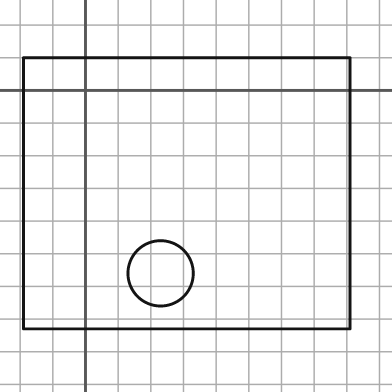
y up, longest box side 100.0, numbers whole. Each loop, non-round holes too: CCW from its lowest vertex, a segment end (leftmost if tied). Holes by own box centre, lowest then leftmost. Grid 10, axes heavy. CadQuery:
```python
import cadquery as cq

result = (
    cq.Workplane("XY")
    .moveTo(-19.0, -73.0)
    .lineTo(81.0, -73.0)
    .lineTo(81.0, 10.0)
    .lineTo(-19.0, 10.0)
    .close()
    .moveTo(23.0, -56.0)
    .circle(10.0)
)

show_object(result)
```